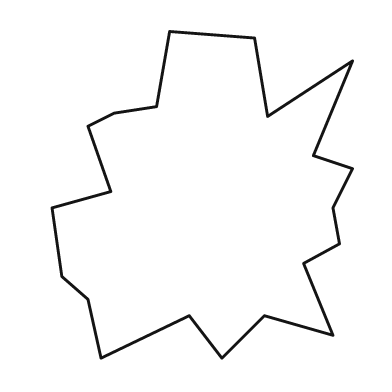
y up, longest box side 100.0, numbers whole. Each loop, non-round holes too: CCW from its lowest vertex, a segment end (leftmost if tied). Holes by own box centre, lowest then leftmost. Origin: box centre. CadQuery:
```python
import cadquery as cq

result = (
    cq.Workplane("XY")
    .moveTo(-31.0, -50.0)
    .lineTo(-4.0, -37.0)
    .lineTo(6.0, -50.0)
    .lineTo(19.0, -37.0)
    .lineTo(40.0, -43.0)
    .lineTo(31.0, -21.0)
    .lineTo(42.0, -15.0)
    .lineTo(40.0, -4.0)
    .lineTo(46.0, 8.0)
    .lineTo(34.0, 12.0)
    .lineTo(46.0, 41.0)
    .lineTo(20.0, 24.0)
    .lineTo(16.0, 48.0)
    .lineTo(-10.0, 50.0)
    .lineTo(-14.0, 27.0)
    .lineTo(-27.0, 25.0)
    .lineTo(-35.0, 21.0)
    .lineTo(-28.0, 1.0)
    .lineTo(-46.0, -4.0)
    .lineTo(-43.0, -25.0)
    .lineTo(-35.0, -32.0)
    .close()
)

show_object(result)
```